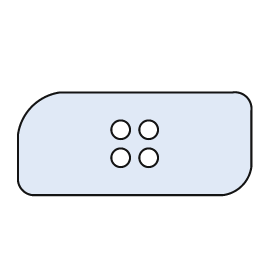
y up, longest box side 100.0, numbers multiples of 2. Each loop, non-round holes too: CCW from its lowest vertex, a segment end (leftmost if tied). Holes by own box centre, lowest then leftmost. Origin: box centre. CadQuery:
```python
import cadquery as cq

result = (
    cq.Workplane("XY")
    .moveTo(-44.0, -22.0)
    .lineTo(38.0, -22.0)
    .threePointArc((46.0, -18.0), (50.0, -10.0))
    .lineTo(50.0, 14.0)
    .threePointArc((48.0, 20.0), (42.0, 22.0))
    .lineTo(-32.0, 22.0)
    .threePointArc((-44.0, 16.0), (-50.0, 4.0))
    .lineTo(-50.0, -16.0)
    .threePointArc((-48.0, -20.0), (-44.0, -22.0))
    .close()
    .moveTo(-6.0, -6.0)
    .circle(4.0)
    .moveTo(6.0, -6.0)
    .circle(4.0)
    .moveTo(-6.0, 6.0)
    .circle(4.0)
    .moveTo(6.0, 6.0)
    .circle(4.0)
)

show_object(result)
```